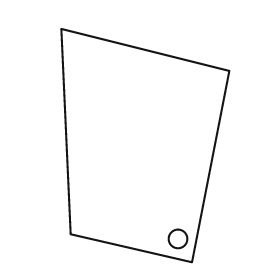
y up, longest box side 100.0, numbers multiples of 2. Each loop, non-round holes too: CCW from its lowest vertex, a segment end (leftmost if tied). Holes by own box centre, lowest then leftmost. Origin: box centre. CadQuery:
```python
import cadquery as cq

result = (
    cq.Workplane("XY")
    .moveTo(20.0, -50.0)
    .lineTo(36.0, 32.0)
    .lineTo(-36.0, 50.0)
    .lineTo(-32.0, -38.0)
    .close()
    .moveTo(14.0, -40.0)
    .circle(4.0)
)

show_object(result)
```